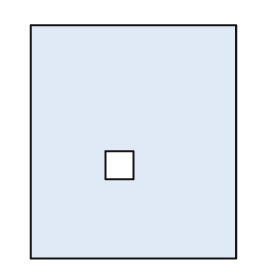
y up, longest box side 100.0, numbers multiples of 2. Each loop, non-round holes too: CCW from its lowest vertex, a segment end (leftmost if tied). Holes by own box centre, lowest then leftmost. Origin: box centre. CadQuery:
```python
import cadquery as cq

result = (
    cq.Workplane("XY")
    .moveTo(-44.0, -50.0)
    .lineTo(44.0, -50.0)
    .lineTo(44.0, 50.0)
    .lineTo(-44.0, 50.0)
    .close()
    .moveTo(-12.0, -16.0)
    .lineTo(0.0, -16.0)
    .lineTo(0.0, -4.0)
    .lineTo(-12.0, -4.0)
    .close()
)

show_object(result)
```